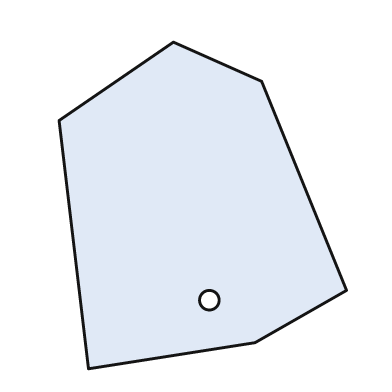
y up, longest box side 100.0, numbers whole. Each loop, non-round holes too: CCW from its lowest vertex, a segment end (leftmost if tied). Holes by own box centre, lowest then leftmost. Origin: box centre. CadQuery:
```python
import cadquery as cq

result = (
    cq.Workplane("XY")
    .moveTo(-35.0, -50.0)
    .lineTo(16.0, -42.0)
    .lineTo(44.0, -26.0)
    .lineTo(18.0, 38.0)
    .lineTo(-9.0, 50.0)
    .lineTo(-44.0, 26.0)
    .close()
    .moveTo(2.0, -29.0)
    .circle(3.0)
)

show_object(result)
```